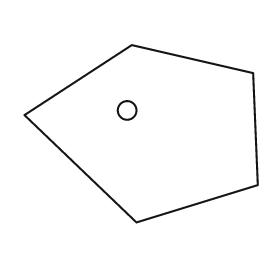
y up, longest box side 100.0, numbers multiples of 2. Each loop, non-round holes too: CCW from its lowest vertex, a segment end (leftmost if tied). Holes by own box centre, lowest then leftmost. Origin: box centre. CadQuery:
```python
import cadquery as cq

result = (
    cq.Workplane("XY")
    .moveTo(-2.0, -38.0)
    .lineTo(50.0, -22.0)
    .lineTo(48.0, 26.0)
    .lineTo(-4.0, 38.0)
    .lineTo(-50.0, 8.0)
    .close()
    .moveTo(-6.0, 10.0)
    .circle(4.0)
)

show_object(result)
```